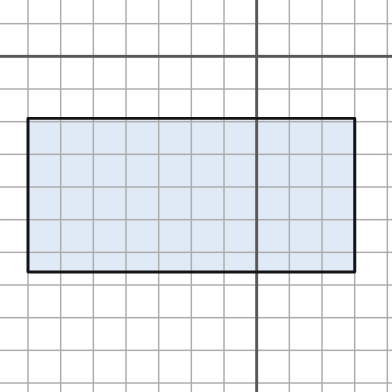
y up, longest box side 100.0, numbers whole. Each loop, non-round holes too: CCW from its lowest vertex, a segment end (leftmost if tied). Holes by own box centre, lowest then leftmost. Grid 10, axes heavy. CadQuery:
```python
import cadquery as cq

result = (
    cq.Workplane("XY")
    .moveTo(-70.0, -66.0)
    .lineTo(30.0, -66.0)
    .lineTo(30.0, -19.0)
    .lineTo(-70.0, -19.0)
    .close()
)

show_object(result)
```